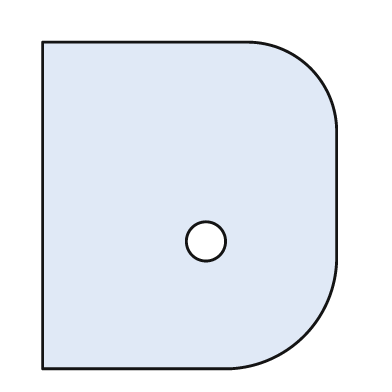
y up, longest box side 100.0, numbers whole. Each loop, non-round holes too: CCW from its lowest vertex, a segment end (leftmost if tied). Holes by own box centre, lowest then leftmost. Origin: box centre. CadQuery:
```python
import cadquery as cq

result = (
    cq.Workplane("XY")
    .moveTo(-45.0, -50.0)
    .lineTo(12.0, -50.0)
    .threePointArc((35.0, -40.0), (45.0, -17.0))
    .lineTo(45.0, 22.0)
    .threePointArc((37.0, 42.0), (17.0, 50.0))
    .lineTo(-45.0, 50.0)
    .close()
    .moveTo(5.0, -11.0)
    .circle(6.0)
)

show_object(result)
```